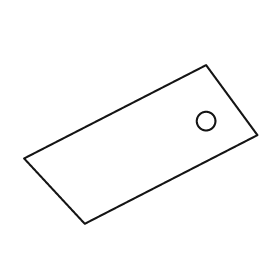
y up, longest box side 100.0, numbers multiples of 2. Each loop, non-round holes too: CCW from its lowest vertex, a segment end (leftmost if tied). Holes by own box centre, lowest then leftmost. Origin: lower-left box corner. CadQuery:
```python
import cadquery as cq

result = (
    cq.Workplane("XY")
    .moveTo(26.0, 0.0)
    .lineTo(100.0, 38.0)
    .lineTo(78.0, 68.0)
    .lineTo(0.0, 28.0)
    .close()
    .moveTo(78.0, 44.0)
    .circle(4.0)
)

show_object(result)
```